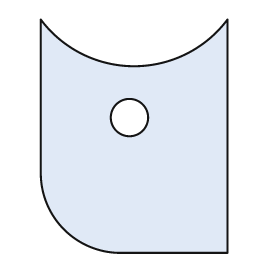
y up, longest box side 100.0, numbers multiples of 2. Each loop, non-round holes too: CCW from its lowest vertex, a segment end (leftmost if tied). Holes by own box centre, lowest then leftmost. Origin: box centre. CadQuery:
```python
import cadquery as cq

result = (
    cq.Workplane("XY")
    .moveTo(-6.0, -50.0)
    .lineTo(40.0, -50.0)
    .lineTo(40.0, 50.0)
    .threePointArc((0.0, 30.0), (-40.0, 50.0))
    .lineTo(-40.0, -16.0)
    .threePointArc((-30.0, -40.0), (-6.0, -50.0))
    .close()
    .moveTo(-2.0, 8.0)
    .circle(8.0)
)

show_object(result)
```